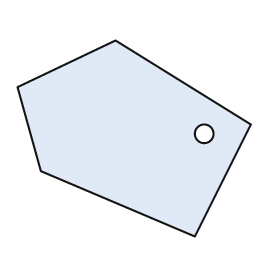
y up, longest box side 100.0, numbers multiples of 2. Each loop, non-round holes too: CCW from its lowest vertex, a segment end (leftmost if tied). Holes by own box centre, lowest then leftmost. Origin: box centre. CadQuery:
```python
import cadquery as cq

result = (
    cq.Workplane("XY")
    .moveTo(26.0, -42.0)
    .lineTo(50.0, 6.0)
    .lineTo(-8.0, 42.0)
    .lineTo(-50.0, 22.0)
    .lineTo(-40.0, -14.0)
    .close()
    .moveTo(30.0, 2.0)
    .circle(4.0)
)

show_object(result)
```